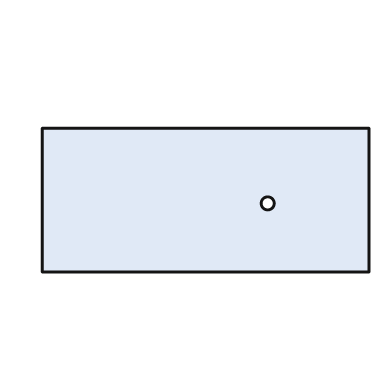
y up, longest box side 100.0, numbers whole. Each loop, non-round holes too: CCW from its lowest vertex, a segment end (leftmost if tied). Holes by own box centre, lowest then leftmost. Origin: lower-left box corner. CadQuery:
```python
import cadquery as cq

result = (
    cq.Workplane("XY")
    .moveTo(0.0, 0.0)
    .lineTo(100.0, 0.0)
    .lineTo(100.0, 44.0)
    .lineTo(0.0, 44.0)
    .close()
    .moveTo(69.0, 21.0)
    .circle(2.0)
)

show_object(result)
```